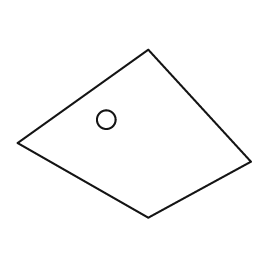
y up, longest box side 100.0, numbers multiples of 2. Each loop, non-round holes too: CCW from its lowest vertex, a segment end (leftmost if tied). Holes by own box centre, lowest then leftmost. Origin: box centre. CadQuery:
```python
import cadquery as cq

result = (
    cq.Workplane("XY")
    .moveTo(6.0, -36.0)
    .lineTo(50.0, -12.0)
    .lineTo(6.0, 36.0)
    .lineTo(-50.0, -4.0)
    .close()
    .moveTo(-12.0, 6.0)
    .circle(4.0)
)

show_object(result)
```